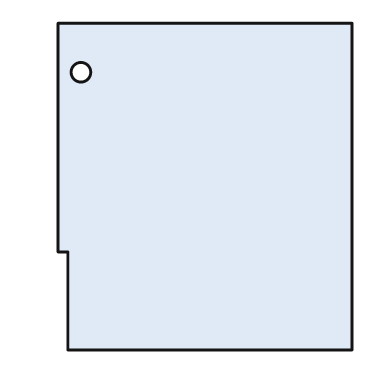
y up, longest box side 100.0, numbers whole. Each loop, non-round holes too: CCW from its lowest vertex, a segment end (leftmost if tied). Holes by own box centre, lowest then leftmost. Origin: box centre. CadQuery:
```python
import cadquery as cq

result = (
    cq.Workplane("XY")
    .moveTo(-42.0, -50.0)
    .lineTo(45.0, -50.0)
    .lineTo(45.0, 50.0)
    .lineTo(-45.0, 50.0)
    .lineTo(-45.0, -20.0)
    .lineTo(-42.0, -20.0)
    .close()
    .moveTo(-38.0, 35.0)
    .circle(3.0)
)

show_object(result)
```